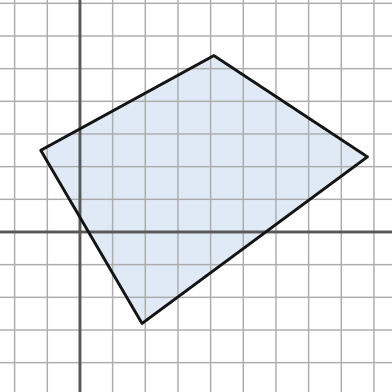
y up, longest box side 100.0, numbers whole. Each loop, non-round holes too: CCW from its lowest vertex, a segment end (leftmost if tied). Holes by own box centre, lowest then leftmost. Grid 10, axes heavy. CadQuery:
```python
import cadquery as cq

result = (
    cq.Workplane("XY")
    .moveTo(19.0, -28.0)
    .lineTo(88.0, 23.0)
    .lineTo(41.0, 54.0)
    .lineTo(-12.0, 25.0)
    .close()
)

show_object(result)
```